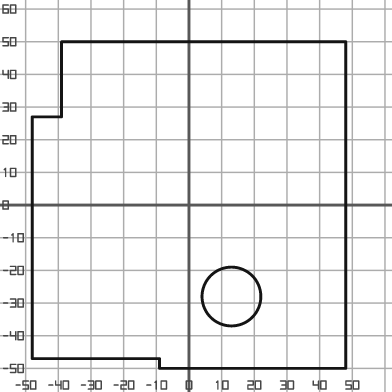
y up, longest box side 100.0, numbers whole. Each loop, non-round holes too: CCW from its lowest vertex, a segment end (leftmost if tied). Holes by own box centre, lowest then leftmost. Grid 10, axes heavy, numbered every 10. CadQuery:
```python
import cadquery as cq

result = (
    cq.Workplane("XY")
    .moveTo(-9.0, -50.0)
    .lineTo(48.0, -50.0)
    .lineTo(48.0, 50.0)
    .lineTo(-39.0, 50.0)
    .lineTo(-39.0, 27.0)
    .lineTo(-48.0, 27.0)
    .lineTo(-48.0, -47.0)
    .lineTo(-9.0, -47.0)
    .close()
    .moveTo(13.0, -28.0)
    .circle(9.0)
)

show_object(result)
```